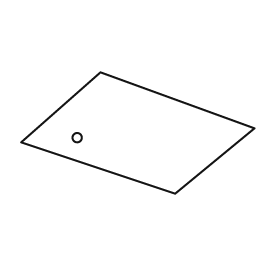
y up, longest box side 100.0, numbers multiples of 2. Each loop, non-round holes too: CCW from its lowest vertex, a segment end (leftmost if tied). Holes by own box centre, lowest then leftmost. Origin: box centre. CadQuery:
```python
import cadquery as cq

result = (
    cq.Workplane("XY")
    .moveTo(16.0, -26.0)
    .lineTo(50.0, 2.0)
    .lineTo(-16.0, 26.0)
    .lineTo(-50.0, -4.0)
    .close()
    .moveTo(-26.0, -2.0)
    .circle(2.0)
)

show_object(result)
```